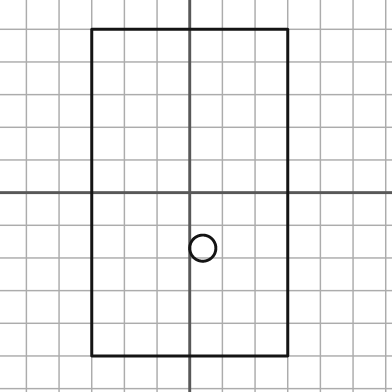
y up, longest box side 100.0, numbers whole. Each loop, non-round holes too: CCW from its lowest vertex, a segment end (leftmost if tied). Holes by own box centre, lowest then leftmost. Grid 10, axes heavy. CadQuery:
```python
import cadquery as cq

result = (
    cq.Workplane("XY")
    .moveTo(-30.0, -50.0)
    .lineTo(30.0, -50.0)
    .lineTo(30.0, 50.0)
    .lineTo(-30.0, 50.0)
    .close()
    .moveTo(4.0, -17.0)
    .circle(4.0)
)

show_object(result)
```